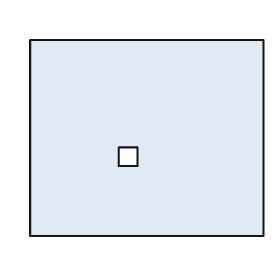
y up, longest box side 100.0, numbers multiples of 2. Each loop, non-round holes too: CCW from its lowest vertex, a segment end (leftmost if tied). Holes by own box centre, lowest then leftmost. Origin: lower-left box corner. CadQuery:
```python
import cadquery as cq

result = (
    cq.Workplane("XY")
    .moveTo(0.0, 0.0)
    .lineTo(100.0, 0.0)
    .lineTo(100.0, 84.0)
    .lineTo(0.0, 84.0)
    .close()
    .moveTo(38.0, 30.0)
    .lineTo(46.0, 30.0)
    .lineTo(46.0, 38.0)
    .lineTo(38.0, 38.0)
    .close()
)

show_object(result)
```